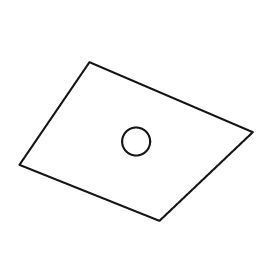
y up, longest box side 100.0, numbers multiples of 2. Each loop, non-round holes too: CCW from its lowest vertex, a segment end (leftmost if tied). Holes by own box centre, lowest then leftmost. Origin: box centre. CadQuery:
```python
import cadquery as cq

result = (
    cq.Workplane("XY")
    .moveTo(10.0, -34.0)
    .lineTo(50.0, 4.0)
    .lineTo(-20.0, 34.0)
    .lineTo(-50.0, -10.0)
    .close()
    .moveTo(0.0, 0.0)
    .circle(6.0)
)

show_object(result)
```